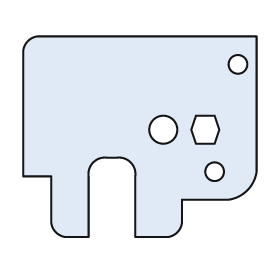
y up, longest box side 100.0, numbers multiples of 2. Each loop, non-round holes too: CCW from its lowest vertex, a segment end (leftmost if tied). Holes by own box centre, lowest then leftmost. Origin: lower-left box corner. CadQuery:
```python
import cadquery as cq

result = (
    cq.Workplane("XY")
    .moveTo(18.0, 0.0)
    .lineTo(28.0, 0.0)
    .lineTo(28.0, 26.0)
    .threePointArc((30.0, 32.0), (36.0, 34.0))
    .lineTo(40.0, 34.0)
    .threePointArc((46.0, 32.0), (48.0, 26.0))
    .lineTo(48.0, 0.0)
    .lineTo(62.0, 0.0)
    .threePointArc((66.0, 2.0), (68.0, 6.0))
    .lineTo(68.0, 16.0)
    .lineTo(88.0, 16.0)
    .threePointArc((96.0, 20.0), (100.0, 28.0))
    .lineTo(100.0, 86.0)
    .lineTo(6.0, 86.0)
    .threePointArc((2.0, 84.0), (0.0, 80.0))
    .lineTo(0.0, 26.0)
    .lineTo(12.0, 26.0)
    .lineTo(12.0, 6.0)
    .threePointArc((14.0, 2.0), (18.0, 0.0))
    .close()
    .moveTo(82.0, 28.0)
    .circle(4.0)
    .moveTo(60.0, 46.0)
    .circle(6.0)
    .moveTo(74.0, 40.0)
    .lineTo(82.0, 40.0)
    .lineTo(84.0, 46.0)
    .lineTo(82.0, 52.0)
    .lineTo(74.0, 52.0)
    .lineTo(72.0, 46.0)
    .close()
    .moveTo(92.0, 74.0)
    .circle(4.0)
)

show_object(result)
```